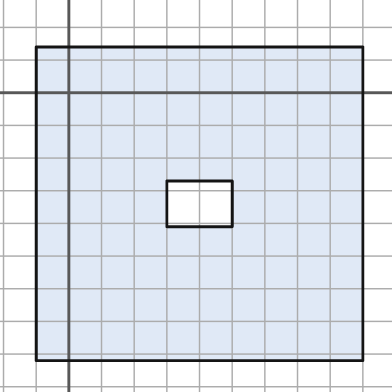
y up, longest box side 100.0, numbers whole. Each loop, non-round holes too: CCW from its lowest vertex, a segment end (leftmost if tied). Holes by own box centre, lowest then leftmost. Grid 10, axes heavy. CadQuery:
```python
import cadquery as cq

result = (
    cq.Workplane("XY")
    .moveTo(-10.0, -82.0)
    .lineTo(90.0, -82.0)
    .lineTo(90.0, 14.0)
    .lineTo(-10.0, 14.0)
    .close()
    .moveTo(30.0, -41.0)
    .lineTo(50.0, -41.0)
    .lineTo(50.0, -27.0)
    .lineTo(30.0, -27.0)
    .close()
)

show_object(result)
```